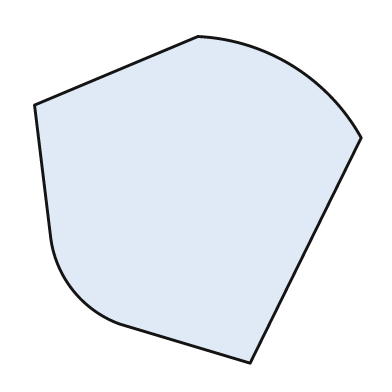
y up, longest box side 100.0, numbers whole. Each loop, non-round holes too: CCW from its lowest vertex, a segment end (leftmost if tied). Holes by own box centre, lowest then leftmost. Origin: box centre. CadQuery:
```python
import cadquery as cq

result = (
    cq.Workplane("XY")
    .moveTo(16.0, -50.0)
    .lineTo(50.0, 19.0)
    .threePointArc((29.0, 41.0), (0.0, 50.0))
    .lineTo(-50.0, 29.0)
    .lineTo(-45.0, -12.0)
    .threePointArc((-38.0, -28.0), (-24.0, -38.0))
    .close()
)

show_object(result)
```